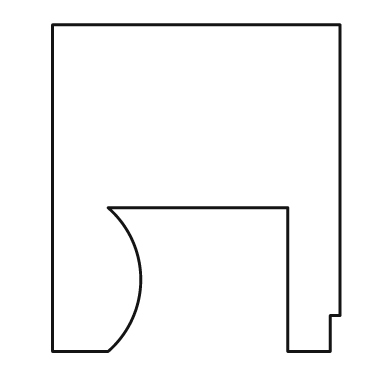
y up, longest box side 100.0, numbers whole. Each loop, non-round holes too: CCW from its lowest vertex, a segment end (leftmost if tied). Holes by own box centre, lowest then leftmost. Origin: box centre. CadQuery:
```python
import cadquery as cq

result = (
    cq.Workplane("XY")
    .moveTo(-44.0, -50.0)
    .lineTo(-27.0, -50.0)
    .threePointArc((-17.0, -28.0), (-27.0, -6.0))
    .lineTo(28.0, -6.0)
    .lineTo(28.0, -50.0)
    .lineTo(41.0, -50.0)
    .lineTo(41.0, -39.0)
    .lineTo(44.0, -39.0)
    .lineTo(44.0, 50.0)
    .lineTo(-44.0, 50.0)
    .close()
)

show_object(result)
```